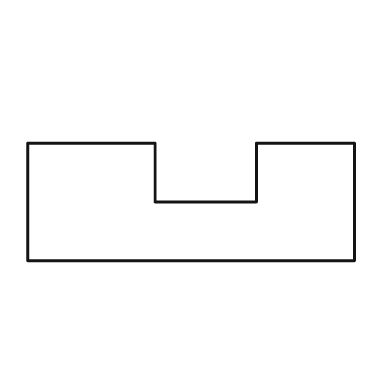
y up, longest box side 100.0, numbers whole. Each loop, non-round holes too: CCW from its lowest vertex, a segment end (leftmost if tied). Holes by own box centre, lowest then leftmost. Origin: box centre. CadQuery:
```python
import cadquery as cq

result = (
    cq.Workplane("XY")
    .moveTo(-50.0, -18.0)
    .lineTo(50.0, -18.0)
    .lineTo(50.0, 18.0)
    .lineTo(20.0, 18.0)
    .lineTo(20.0, 0.0)
    .lineTo(-11.0, 0.0)
    .lineTo(-11.0, 18.0)
    .lineTo(-50.0, 18.0)
    .close()
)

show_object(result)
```